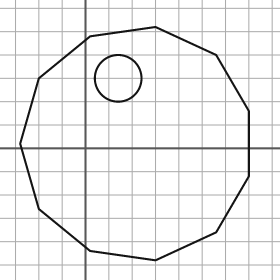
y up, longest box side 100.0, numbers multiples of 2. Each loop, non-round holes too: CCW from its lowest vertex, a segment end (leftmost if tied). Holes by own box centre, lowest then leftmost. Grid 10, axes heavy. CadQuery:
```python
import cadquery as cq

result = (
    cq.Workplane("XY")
    .moveTo(30.0, -48.0)
    .lineTo(56.0, -36.0)
    .lineTo(70.0, -12.0)
    .lineTo(70.0, 16.0)
    .lineTo(56.0, 40.0)
    .lineTo(30.0, 52.0)
    .lineTo(2.0, 48.0)
    .lineTo(-20.0, 30.0)
    .lineTo(-28.0, 2.0)
    .lineTo(-20.0, -26.0)
    .lineTo(2.0, -44.0)
    .close()
    .moveTo(14.0, 30.0)
    .circle(10.0)
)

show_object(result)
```